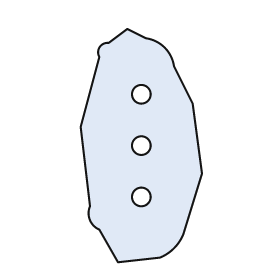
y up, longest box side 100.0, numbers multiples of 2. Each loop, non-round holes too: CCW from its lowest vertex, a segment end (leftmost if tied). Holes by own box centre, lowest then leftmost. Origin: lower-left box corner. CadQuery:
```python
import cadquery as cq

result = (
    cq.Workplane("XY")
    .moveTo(16.0, 0.0)
    .lineTo(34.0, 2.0)
    .threePointArc((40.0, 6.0), (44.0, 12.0))
    .lineTo(52.0, 38.0)
    .lineTo(48.0, 68.0)
    .lineTo(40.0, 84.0)
    .threePointArc((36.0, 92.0), (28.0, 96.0))
    .lineTo(20.0, 100.0)
    .lineTo(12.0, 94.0)
    .threePointArc((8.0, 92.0), (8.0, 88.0))
    .lineTo(0.0, 58.0)
    .lineTo(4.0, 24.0)
    .threePointArc((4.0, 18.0), (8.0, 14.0))
    .close()
    .moveTo(26.0, 28.0)
    .circle(4.0)
    .moveTo(26.0, 50.0)
    .circle(4.0)
    .moveTo(26.0, 72.0)
    .circle(4.0)
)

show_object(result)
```